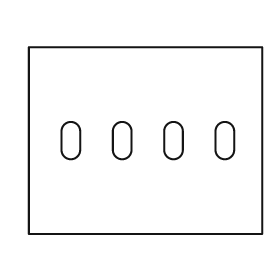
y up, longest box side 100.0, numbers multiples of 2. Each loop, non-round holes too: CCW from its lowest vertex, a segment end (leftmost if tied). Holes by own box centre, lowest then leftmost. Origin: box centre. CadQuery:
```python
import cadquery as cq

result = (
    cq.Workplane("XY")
    .moveTo(-50.0, -40.0)
    .lineTo(50.0, -40.0)
    .lineTo(50.0, 40.0)
    .lineTo(-50.0, 40.0)
    .close()
    .moveTo(-36.0, -4.0)
    .threePointArc((-32.0, -8.0), (-28.0, -4.0))
    .lineTo(-28.0, 4.0)
    .threePointArc((-32.0, 8.0), (-36.0, 4.0))
    .close()
    .moveTo(-14.0, -4.0)
    .threePointArc((-10.0, -8.0), (-6.0, -4.0))
    .lineTo(-6.0, 4.0)
    .threePointArc((-10.0, 8.0), (-14.0, 4.0))
    .close()
    .moveTo(8.0, -4.0)
    .threePointArc((12.0, -8.0), (16.0, -4.0))
    .lineTo(16.0, 4.0)
    .threePointArc((12.0, 8.0), (8.0, 4.0))
    .close()
    .moveTo(30.0, -4.0)
    .threePointArc((34.0, -8.0), (38.0, -4.0))
    .lineTo(38.0, 4.0)
    .threePointArc((34.0, 8.0), (30.0, 4.0))
    .close()
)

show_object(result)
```